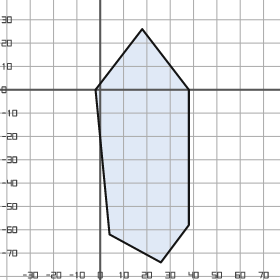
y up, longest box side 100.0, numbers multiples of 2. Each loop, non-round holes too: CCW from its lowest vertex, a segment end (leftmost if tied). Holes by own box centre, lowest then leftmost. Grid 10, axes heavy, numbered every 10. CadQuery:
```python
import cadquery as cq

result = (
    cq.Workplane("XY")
    .moveTo(26.0, -74.0)
    .lineTo(38.0, -58.0)
    .lineTo(38.0, 0.0)
    .lineTo(18.0, 26.0)
    .lineTo(-2.0, 0.0)
    .lineTo(4.0, -62.0)
    .close()
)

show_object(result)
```